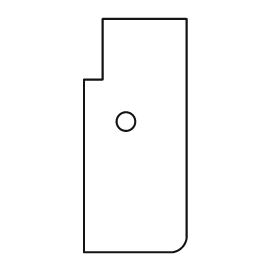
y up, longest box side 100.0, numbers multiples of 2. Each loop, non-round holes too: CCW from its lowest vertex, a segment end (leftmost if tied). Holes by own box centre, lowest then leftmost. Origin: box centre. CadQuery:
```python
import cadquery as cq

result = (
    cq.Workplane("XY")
    .moveTo(-22.0, -50.0)
    .lineTo(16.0, -50.0)
    .threePointArc((20.0, -48.0), (22.0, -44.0))
    .lineTo(22.0, 50.0)
    .lineTo(-14.0, 50.0)
    .lineTo(-14.0, 24.0)
    .lineTo(-22.0, 24.0)
    .close()
    .moveTo(-4.0, 6.0)
    .circle(4.0)
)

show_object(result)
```